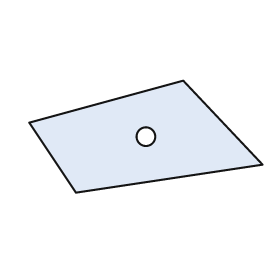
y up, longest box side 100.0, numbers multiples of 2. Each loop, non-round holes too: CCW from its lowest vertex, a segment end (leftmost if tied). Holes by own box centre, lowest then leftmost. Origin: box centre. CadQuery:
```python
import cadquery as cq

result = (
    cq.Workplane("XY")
    .moveTo(-30.0, -24.0)
    .lineTo(50.0, -12.0)
    .lineTo(16.0, 24.0)
    .lineTo(-50.0, 6.0)
    .close()
    .moveTo(0.0, 0.0)
    .circle(4.0)
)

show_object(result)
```